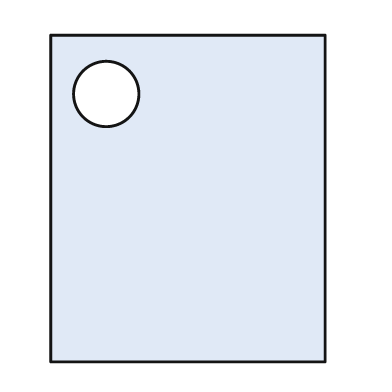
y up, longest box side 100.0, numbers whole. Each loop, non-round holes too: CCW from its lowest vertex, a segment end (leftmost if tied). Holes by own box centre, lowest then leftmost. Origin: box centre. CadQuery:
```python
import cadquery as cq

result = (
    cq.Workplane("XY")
    .moveTo(-42.0, -50.0)
    .lineTo(42.0, -50.0)
    .lineTo(42.0, 50.0)
    .lineTo(-42.0, 50.0)
    .close()
    .moveTo(-25.0, 32.0)
    .circle(10.0)
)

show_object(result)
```